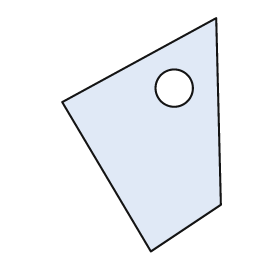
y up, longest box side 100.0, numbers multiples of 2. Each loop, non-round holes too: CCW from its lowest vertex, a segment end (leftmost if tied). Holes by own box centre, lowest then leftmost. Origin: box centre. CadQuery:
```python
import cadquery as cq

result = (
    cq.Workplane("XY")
    .moveTo(4.0, -50.0)
    .lineTo(34.0, -30.0)
    .lineTo(32.0, 50.0)
    .lineTo(-34.0, 14.0)
    .close()
    .moveTo(14.0, 20.0)
    .circle(8.0)
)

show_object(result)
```